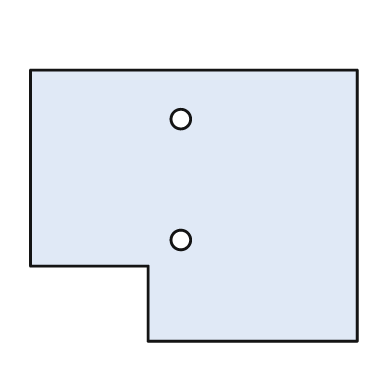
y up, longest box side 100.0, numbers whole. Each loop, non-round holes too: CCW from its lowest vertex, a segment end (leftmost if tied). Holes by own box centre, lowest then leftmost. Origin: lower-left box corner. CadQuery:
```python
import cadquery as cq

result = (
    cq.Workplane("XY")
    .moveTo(36.0, 0.0)
    .lineTo(100.0, 0.0)
    .lineTo(100.0, 83.0)
    .lineTo(0.0, 83.0)
    .lineTo(0.0, 23.0)
    .lineTo(36.0, 23.0)
    .close()
    .moveTo(46.0, 31.0)
    .circle(3.0)
    .moveTo(46.0, 68.0)
    .circle(3.0)
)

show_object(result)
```